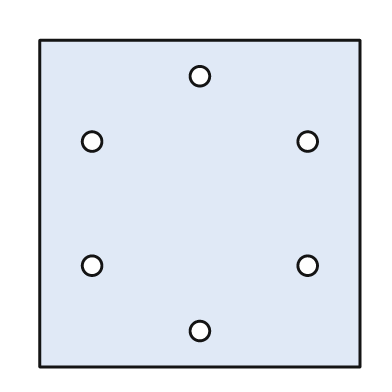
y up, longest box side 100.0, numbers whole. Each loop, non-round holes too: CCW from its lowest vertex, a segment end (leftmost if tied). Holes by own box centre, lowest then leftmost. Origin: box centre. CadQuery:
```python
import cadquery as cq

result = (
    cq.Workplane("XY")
    .moveTo(-49.0, -50.0)
    .lineTo(49.0, -50.0)
    .lineTo(49.0, 50.0)
    .lineTo(-49.0, 50.0)
    .close()
    .moveTo(0.0, -39.0)
    .circle(3.0)
    .moveTo(-33.0, -19.0)
    .circle(3.0)
    .moveTo(33.0, -19.0)
    .circle(3.0)
    .moveTo(-33.0, 19.0)
    .circle(3.0)
    .moveTo(33.0, 19.0)
    .circle(3.0)
    .moveTo(0.0, 39.0)
    .circle(3.0)
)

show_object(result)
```